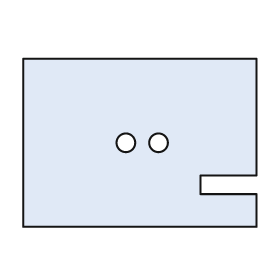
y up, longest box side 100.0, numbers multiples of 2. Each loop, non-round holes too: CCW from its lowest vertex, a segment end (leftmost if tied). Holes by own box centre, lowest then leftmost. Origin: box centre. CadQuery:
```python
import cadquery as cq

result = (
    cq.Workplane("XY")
    .moveTo(-50.0, -36.0)
    .lineTo(50.0, -36.0)
    .lineTo(50.0, -22.0)
    .lineTo(26.0, -22.0)
    .lineTo(26.0, -14.0)
    .lineTo(50.0, -14.0)
    .lineTo(50.0, 36.0)
    .lineTo(-50.0, 36.0)
    .close()
    .moveTo(-6.0, 0.0)
    .circle(4.0)
    .moveTo(8.0, 0.0)
    .circle(4.0)
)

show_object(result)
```